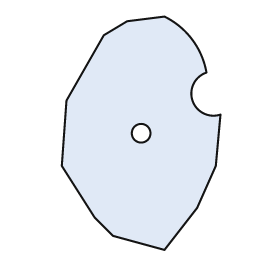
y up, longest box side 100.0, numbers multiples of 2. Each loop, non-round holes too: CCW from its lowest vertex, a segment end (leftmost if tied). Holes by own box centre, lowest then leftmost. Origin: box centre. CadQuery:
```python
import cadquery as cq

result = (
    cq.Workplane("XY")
    .moveTo(10.0, -50.0)
    .lineTo(24.0, -32.0)
    .lineTo(32.0, -14.0)
    .lineTo(34.0, 8.0)
    .threePointArc((22.0, 14.0), (28.0, 26.0))
    .threePointArc((22.0, 40.0), (10.0, 50.0))
    .lineTo(-6.0, 48.0)
    .lineTo(-16.0, 42.0)
    .lineTo(-32.0, 14.0)
    .lineTo(-34.0, -14.0)
    .lineTo(-20.0, -36.0)
    .lineTo(-12.0, -44.0)
    .close()
    .moveTo(0.0, 0.0)
    .circle(4.0)
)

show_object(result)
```